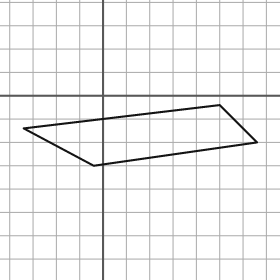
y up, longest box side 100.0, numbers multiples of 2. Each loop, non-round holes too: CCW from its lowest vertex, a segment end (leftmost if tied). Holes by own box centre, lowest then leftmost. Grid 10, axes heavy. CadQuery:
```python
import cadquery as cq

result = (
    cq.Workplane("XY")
    .moveTo(-4.0, -30.0)
    .lineTo(66.0, -20.0)
    .lineTo(50.0, -4.0)
    .lineTo(-34.0, -14.0)
    .close()
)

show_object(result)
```